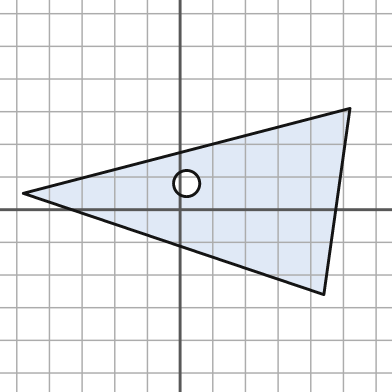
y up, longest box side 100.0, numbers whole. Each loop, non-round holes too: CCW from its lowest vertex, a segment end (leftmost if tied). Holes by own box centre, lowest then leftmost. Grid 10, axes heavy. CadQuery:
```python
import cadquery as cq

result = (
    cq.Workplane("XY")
    .moveTo(44.0, -26.0)
    .lineTo(52.0, 31.0)
    .lineTo(-48.0, 5.0)
    .close()
    .moveTo(2.0, 8.0)
    .circle(4.0)
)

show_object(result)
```